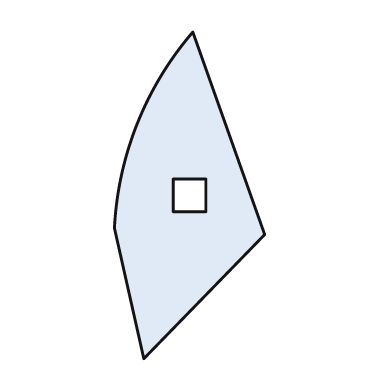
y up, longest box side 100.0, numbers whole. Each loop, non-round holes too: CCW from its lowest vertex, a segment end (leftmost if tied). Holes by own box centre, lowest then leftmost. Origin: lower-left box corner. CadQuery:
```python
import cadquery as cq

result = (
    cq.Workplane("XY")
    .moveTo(9.0, 0.0)
    .lineTo(46.0, 38.0)
    .lineTo(24.0, 100.0)
    .threePointArc((7.0, 72.0), (0.0, 40.0))
    .close()
    .moveTo(18.0, 45.0)
    .lineTo(28.0, 45.0)
    .lineTo(28.0, 55.0)
    .lineTo(18.0, 55.0)
    .close()
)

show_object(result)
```